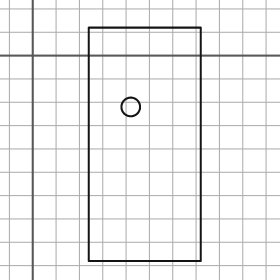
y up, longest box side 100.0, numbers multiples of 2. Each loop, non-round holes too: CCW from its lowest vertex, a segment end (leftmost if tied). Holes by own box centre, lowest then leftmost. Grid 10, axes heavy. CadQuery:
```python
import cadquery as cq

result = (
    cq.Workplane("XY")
    .moveTo(24.0, -88.0)
    .lineTo(72.0, -88.0)
    .lineTo(72.0, 12.0)
    .lineTo(24.0, 12.0)
    .close()
    .moveTo(42.0, -22.0)
    .circle(4.0)
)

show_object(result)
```